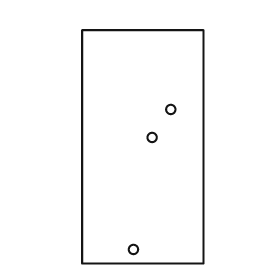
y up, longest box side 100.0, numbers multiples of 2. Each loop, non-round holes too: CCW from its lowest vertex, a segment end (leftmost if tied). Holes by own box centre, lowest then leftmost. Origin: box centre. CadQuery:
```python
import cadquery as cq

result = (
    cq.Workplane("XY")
    .moveTo(-26.0, -50.0)
    .lineTo(26.0, -50.0)
    .lineTo(26.0, 50.0)
    .lineTo(-26.0, 50.0)
    .close()
    .moveTo(-4.0, -44.0)
    .circle(2.0)
    .moveTo(4.0, 4.0)
    .circle(2.0)
    .moveTo(12.0, 16.0)
    .circle(2.0)
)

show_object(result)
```